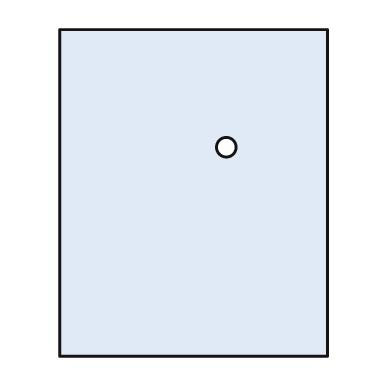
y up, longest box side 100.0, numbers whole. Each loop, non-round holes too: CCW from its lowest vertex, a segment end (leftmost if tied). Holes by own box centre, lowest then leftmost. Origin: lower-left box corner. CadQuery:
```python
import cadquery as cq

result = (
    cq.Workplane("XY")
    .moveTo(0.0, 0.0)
    .lineTo(82.0, 0.0)
    .lineTo(82.0, 100.0)
    .lineTo(0.0, 100.0)
    .close()
    .moveTo(51.0, 64.0)
    .circle(3.0)
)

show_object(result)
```